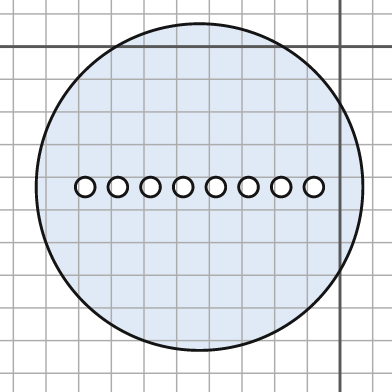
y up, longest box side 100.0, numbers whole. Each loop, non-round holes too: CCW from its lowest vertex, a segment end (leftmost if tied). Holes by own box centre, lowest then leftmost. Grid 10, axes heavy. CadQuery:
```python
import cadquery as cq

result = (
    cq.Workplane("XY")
    .moveTo(-43.0, -43.0)
    .circle(50.0)
    .moveTo(-78.0, -43.0)
    .circle(3.0)
    .moveTo(-68.0, -43.0)
    .circle(3.0)
    .moveTo(-58.0, -43.0)
    .circle(3.0)
    .moveTo(-48.0, -43.0)
    .circle(3.0)
    .moveTo(-38.0, -43.0)
    .circle(3.0)
    .moveTo(-28.0, -43.0)
    .circle(3.0)
    .moveTo(-18.0, -43.0)
    .circle(3.0)
    .moveTo(-8.0, -43.0)
    .circle(3.0)
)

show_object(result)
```